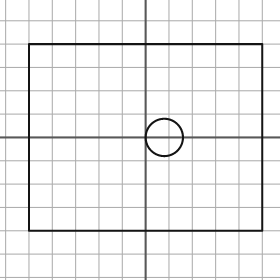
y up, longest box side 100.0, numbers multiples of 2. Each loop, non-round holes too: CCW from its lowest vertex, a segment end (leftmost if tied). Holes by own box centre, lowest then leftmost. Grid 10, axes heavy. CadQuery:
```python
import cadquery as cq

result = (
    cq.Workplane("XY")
    .moveTo(-50.0, -40.0)
    .lineTo(50.0, -40.0)
    .lineTo(50.0, 40.0)
    .lineTo(-50.0, 40.0)
    .close()
    .moveTo(8.0, 0.0)
    .circle(8.0)
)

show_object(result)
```